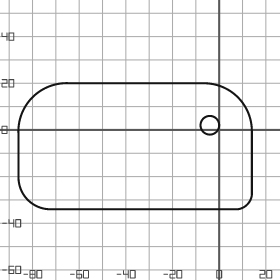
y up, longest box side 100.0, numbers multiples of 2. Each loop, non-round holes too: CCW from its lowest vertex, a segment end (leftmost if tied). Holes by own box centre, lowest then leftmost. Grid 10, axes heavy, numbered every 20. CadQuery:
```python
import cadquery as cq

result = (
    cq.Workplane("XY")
    .moveTo(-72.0, -34.0)
    .lineTo(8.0, -34.0)
    .threePointArc((12.0, -32.0), (14.0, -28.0))
    .lineTo(14.0, 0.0)
    .threePointArc((8.0, 14.0), (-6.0, 20.0))
    .lineTo(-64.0, 20.0)
    .threePointArc((-80.0, 14.0), (-86.0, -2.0))
    .lineTo(-86.0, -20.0)
    .threePointArc((-82.0, -30.0), (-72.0, -34.0))
    .close()
    .moveTo(-4.0, 2.0)
    .circle(4.0)
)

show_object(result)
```